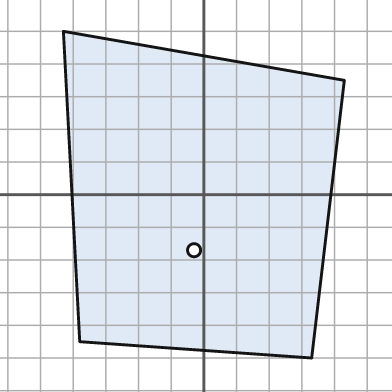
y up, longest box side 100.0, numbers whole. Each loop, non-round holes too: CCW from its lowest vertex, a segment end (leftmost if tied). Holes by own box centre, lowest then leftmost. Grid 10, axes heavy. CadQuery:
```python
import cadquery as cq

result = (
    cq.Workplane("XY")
    .moveTo(33.0, -50.0)
    .lineTo(43.0, 35.0)
    .lineTo(-43.0, 50.0)
    .lineTo(-38.0, -45.0)
    .close()
    .moveTo(-3.0, -17.0)
    .circle(2.0)
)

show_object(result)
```